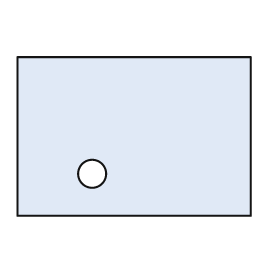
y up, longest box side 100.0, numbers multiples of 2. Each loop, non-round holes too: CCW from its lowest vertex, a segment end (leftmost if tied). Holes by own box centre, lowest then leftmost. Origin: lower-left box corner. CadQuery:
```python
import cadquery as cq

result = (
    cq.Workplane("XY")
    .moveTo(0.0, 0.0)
    .lineTo(100.0, 0.0)
    .lineTo(100.0, 68.0)
    .lineTo(0.0, 68.0)
    .close()
    .moveTo(32.0, 18.0)
    .circle(6.0)
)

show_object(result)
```